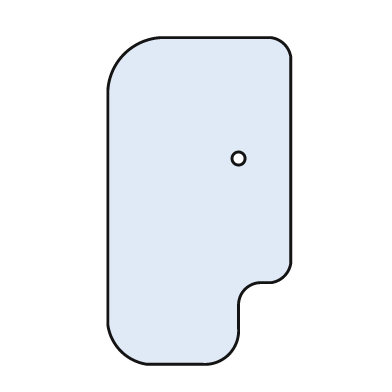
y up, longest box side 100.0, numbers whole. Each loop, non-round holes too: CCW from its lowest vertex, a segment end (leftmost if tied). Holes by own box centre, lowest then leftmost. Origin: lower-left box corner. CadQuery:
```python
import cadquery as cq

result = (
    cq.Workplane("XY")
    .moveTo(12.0, 0.0)
    .lineTo(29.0, 0.0)
    .threePointArc((37.0, 3.0), (40.0, 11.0))
    .lineTo(40.0, 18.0)
    .threePointArc((42.0, 23.0), (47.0, 25.0))
    .lineTo(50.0, 25.0)
    .threePointArc((54.0, 27.0), (56.0, 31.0))
    .lineTo(56.0, 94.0)
    .threePointArc((54.0, 98.0), (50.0, 100.0))
    .lineTo(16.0, 100.0)
    .threePointArc((5.0, 95.0), (0.0, 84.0))
    .lineTo(0.0, 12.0)
    .threePointArc((4.0, 4.0), (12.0, 0.0))
    .close()
    .moveTo(40.0, 63.0)
    .circle(2.0)
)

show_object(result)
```